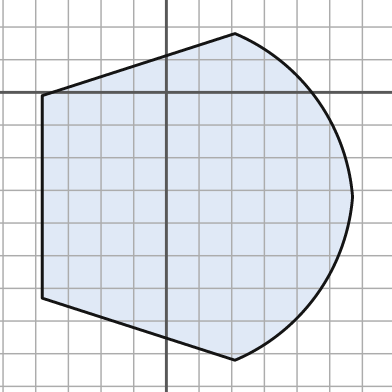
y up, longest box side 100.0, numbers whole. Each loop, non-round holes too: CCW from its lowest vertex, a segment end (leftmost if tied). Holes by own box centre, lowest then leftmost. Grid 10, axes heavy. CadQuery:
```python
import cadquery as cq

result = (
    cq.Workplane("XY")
    .moveTo(21.0, -82.0)
    .threePointArc((46.0, -62.0), (57.0, -32.0))
    .threePointArc((46.0, -2.0), (21.0, 18.0))
    .lineTo(-38.0, -1.0)
    .lineTo(-38.0, -63.0)
    .close()
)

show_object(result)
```